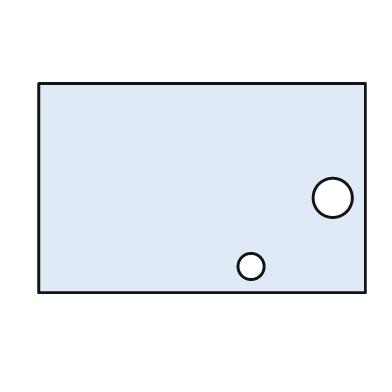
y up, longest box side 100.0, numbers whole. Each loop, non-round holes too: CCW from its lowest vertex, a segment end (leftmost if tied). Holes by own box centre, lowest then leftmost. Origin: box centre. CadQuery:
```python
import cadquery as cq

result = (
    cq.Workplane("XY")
    .moveTo(-50.0, -32.0)
    .lineTo(50.0, -32.0)
    .lineTo(50.0, 32.0)
    .lineTo(-50.0, 32.0)
    .close()
    .moveTo(15.0, -24.0)
    .circle(4.0)
    .moveTo(40.0, -3.0)
    .circle(6.0)
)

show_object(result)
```